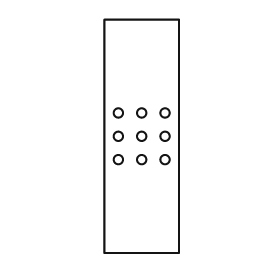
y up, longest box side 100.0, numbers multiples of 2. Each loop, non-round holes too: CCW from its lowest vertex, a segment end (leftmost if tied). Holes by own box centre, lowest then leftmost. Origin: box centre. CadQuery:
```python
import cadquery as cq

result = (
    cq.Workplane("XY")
    .moveTo(-16.0, -50.0)
    .lineTo(16.0, -50.0)
    .lineTo(16.0, 50.0)
    .lineTo(-16.0, 50.0)
    .close()
    .moveTo(-10.0, -10.0)
    .circle(2.0)
    .moveTo(0.0, -10.0)
    .circle(2.0)
    .moveTo(10.0, -10.0)
    .circle(2.0)
    .moveTo(-10.0, 0.0)
    .circle(2.0)
    .moveTo(0.0, 0.0)
    .circle(2.0)
    .moveTo(10.0, 0.0)
    .circle(2.0)
    .moveTo(-10.0, 10.0)
    .circle(2.0)
    .moveTo(0.0, 10.0)
    .circle(2.0)
    .moveTo(10.0, 10.0)
    .circle(2.0)
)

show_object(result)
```